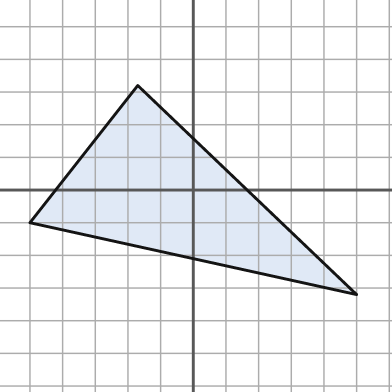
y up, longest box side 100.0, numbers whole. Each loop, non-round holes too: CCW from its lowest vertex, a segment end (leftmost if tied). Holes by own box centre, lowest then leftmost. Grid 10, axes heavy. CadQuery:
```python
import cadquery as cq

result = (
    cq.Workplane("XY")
    .moveTo(50.0, -32.0)
    .lineTo(-17.0, 32.0)
    .lineTo(-50.0, -10.0)
    .close()
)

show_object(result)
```